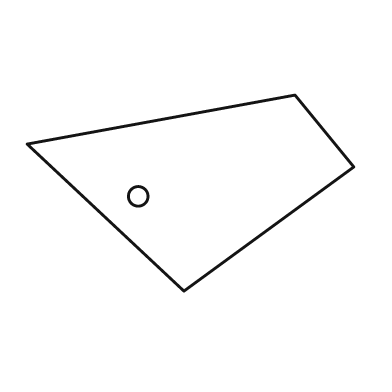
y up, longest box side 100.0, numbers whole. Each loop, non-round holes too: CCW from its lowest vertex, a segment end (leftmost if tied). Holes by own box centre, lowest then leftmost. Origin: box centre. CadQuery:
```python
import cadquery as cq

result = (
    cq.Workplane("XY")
    .moveTo(-2.0, -30.0)
    .lineTo(50.0, 8.0)
    .lineTo(32.0, 30.0)
    .lineTo(-50.0, 15.0)
    .close()
    .moveTo(-16.0, -1.0)
    .circle(3.0)
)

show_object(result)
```